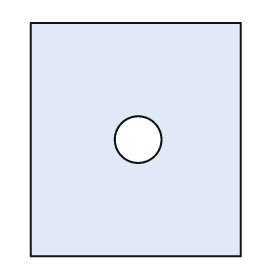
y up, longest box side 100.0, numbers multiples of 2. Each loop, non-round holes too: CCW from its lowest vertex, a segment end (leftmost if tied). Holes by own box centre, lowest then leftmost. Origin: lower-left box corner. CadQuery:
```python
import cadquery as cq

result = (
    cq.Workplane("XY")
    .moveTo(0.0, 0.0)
    .lineTo(90.0, 0.0)
    .lineTo(90.0, 100.0)
    .lineTo(0.0, 100.0)
    .close()
    .moveTo(46.0, 50.0)
    .circle(10.0)
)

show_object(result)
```